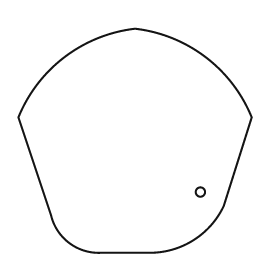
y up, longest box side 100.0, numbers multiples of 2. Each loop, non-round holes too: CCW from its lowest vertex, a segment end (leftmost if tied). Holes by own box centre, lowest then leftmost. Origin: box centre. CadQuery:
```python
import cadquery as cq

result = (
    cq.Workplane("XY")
    .moveTo(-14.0, -48.0)
    .lineTo(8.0, -48.0)
    .threePointArc((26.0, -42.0), (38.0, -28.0))
    .lineTo(50.0, 10.0)
    .threePointArc((30.0, 36.0), (0.0, 48.0))
    .threePointArc((-30.0, 36.0), (-50.0, 10.0))
    .lineTo(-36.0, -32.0)
    .threePointArc((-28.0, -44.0), (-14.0, -48.0))
    .close()
    .moveTo(28.0, -22.0)
    .circle(2.0)
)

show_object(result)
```